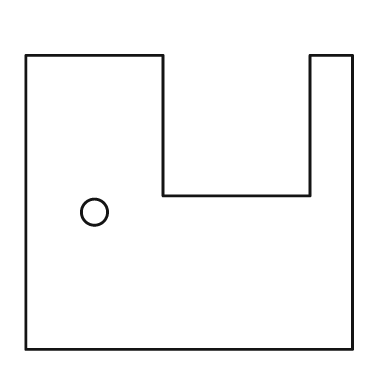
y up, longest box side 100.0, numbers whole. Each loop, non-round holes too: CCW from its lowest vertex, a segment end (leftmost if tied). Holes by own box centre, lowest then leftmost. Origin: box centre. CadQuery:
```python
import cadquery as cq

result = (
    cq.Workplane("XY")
    .moveTo(-50.0, -45.0)
    .lineTo(50.0, -45.0)
    .lineTo(50.0, 45.0)
    .lineTo(37.0, 45.0)
    .lineTo(37.0, 2.0)
    .lineTo(-8.0, 2.0)
    .lineTo(-8.0, 45.0)
    .lineTo(-50.0, 45.0)
    .close()
    .moveTo(-29.0, -3.0)
    .circle(4.0)
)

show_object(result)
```